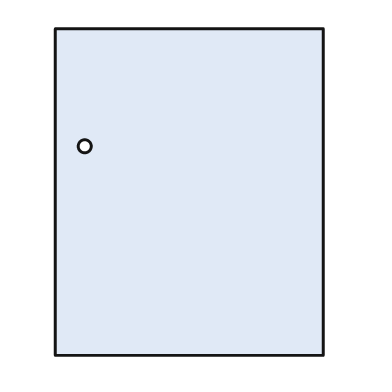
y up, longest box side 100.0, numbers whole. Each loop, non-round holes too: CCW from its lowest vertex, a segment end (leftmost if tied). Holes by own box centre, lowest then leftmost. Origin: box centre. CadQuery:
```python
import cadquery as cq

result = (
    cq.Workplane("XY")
    .moveTo(-41.0, -50.0)
    .lineTo(41.0, -50.0)
    .lineTo(41.0, 50.0)
    .lineTo(-41.0, 50.0)
    .close()
    .moveTo(-32.0, 14.0)
    .circle(2.0)
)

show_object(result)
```